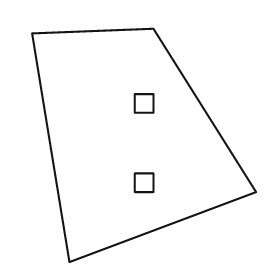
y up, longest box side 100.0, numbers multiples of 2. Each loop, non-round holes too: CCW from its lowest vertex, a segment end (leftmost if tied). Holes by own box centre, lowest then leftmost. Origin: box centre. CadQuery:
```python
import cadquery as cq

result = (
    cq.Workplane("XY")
    .moveTo(-32.0, -50.0)
    .lineTo(48.0, -20.0)
    .lineTo(4.0, 50.0)
    .lineTo(-48.0, 48.0)
    .close()
    .moveTo(-4.0, -20.0)
    .lineTo(4.0, -20.0)
    .lineTo(4.0, -12.0)
    .lineTo(-4.0, -12.0)
    .close()
    .moveTo(-4.0, 14.0)
    .lineTo(4.0, 14.0)
    .lineTo(4.0, 22.0)
    .lineTo(-4.0, 22.0)
    .close()
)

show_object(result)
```